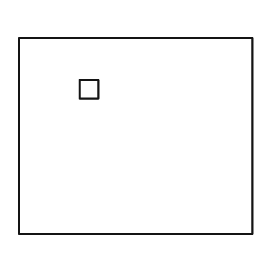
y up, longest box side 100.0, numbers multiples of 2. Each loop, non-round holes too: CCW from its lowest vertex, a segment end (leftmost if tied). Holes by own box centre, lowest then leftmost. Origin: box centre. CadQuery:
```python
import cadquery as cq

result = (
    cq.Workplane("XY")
    .moveTo(-50.0, -42.0)
    .lineTo(50.0, -42.0)
    .lineTo(50.0, 42.0)
    .lineTo(-50.0, 42.0)
    .close()
    .moveTo(-24.0, 16.0)
    .lineTo(-16.0, 16.0)
    .lineTo(-16.0, 24.0)
    .lineTo(-24.0, 24.0)
    .close()
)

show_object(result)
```